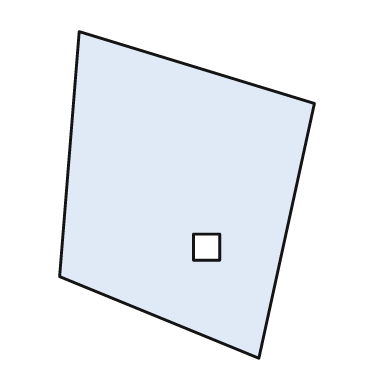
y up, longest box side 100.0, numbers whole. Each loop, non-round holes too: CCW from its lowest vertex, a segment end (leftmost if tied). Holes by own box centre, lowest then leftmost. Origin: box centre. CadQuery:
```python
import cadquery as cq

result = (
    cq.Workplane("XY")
    .moveTo(22.0, -50.0)
    .lineTo(39.0, 28.0)
    .lineTo(-33.0, 50.0)
    .lineTo(-39.0, -25.0)
    .close()
    .moveTo(2.0, -20.0)
    .lineTo(10.0, -20.0)
    .lineTo(10.0, -12.0)
    .lineTo(2.0, -12.0)
    .close()
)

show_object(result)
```